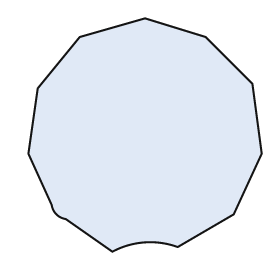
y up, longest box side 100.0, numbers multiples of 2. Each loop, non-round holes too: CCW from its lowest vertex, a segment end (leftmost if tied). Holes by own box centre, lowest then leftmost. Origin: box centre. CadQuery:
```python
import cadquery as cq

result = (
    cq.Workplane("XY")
    .moveTo(-14.0, -50.0)
    .threePointArc((0.0, -46.0), (14.0, -48.0))
    .lineTo(38.0, -34.0)
    .lineTo(50.0, -8.0)
    .lineTo(46.0, 22.0)
    .lineTo(26.0, 42.0)
    .lineTo(0.0, 50.0)
    .lineTo(-28.0, 42.0)
    .lineTo(-46.0, 20.0)
    .lineTo(-50.0, -8.0)
    .lineTo(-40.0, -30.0)
    .threePointArc((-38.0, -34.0), (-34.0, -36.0))
    .close()
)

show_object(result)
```